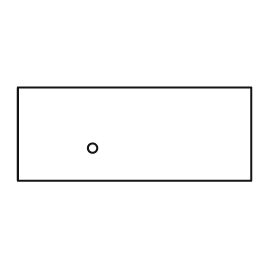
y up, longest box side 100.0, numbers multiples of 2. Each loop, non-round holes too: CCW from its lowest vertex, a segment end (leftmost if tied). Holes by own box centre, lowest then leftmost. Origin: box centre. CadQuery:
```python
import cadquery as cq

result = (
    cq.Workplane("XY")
    .moveTo(-50.0, -20.0)
    .lineTo(50.0, -20.0)
    .lineTo(50.0, 20.0)
    .lineTo(-50.0, 20.0)
    .close()
    .moveTo(-18.0, -6.0)
    .circle(2.0)
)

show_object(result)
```